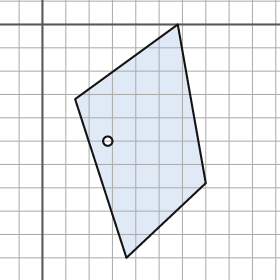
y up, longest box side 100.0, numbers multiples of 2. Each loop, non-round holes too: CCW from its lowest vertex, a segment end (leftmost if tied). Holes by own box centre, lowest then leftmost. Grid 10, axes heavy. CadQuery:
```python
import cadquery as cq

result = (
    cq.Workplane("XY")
    .moveTo(36.0, -100.0)
    .lineTo(70.0, -68.0)
    .lineTo(58.0, 0.0)
    .lineTo(14.0, -32.0)
    .close()
    .moveTo(28.0, -50.0)
    .circle(2.0)
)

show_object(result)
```